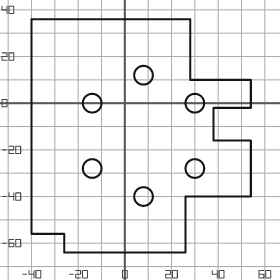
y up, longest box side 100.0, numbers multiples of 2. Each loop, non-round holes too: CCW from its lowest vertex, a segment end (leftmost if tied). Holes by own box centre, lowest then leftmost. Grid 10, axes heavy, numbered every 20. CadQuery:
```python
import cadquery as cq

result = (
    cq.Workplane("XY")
    .moveTo(-26.0, -64.0)
    .lineTo(26.0, -64.0)
    .lineTo(26.0, -40.0)
    .lineTo(54.0, -40.0)
    .lineTo(54.0, -16.0)
    .lineTo(38.0, -16.0)
    .lineTo(38.0, -2.0)
    .lineTo(54.0, -2.0)
    .lineTo(54.0, 10.0)
    .lineTo(28.0, 10.0)
    .lineTo(28.0, 36.0)
    .lineTo(-40.0, 36.0)
    .lineTo(-40.0, -56.0)
    .lineTo(-26.0, -56.0)
    .close()
    .moveTo(8.0, -40.0)
    .circle(4.0)
    .moveTo(-14.0, -28.0)
    .circle(4.0)
    .moveTo(30.0, -28.0)
    .circle(4.0)
    .moveTo(-14.0, 0.0)
    .circle(4.0)
    .moveTo(30.0, 0.0)
    .circle(4.0)
    .moveTo(8.0, 12.0)
    .circle(4.0)
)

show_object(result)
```